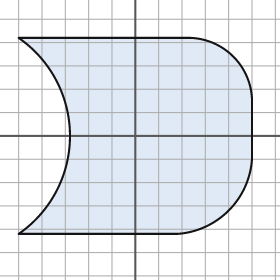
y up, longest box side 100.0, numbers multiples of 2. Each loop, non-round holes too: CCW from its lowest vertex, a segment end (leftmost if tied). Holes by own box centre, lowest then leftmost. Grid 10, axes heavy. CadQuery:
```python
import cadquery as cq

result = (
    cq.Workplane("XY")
    .moveTo(-50.0, -42.0)
    .lineTo(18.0, -42.0)
    .threePointArc((40.0, -32.0), (50.0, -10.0))
    .lineTo(50.0, 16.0)
    .threePointArc((42.0, 34.0), (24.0, 42.0))
    .lineTo(-50.0, 42.0)
    .threePointArc((-28.0, 0.0), (-50.0, -42.0))
    .close()
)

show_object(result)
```